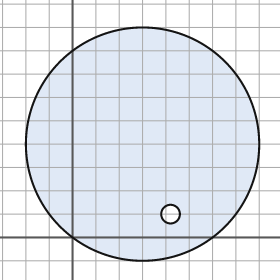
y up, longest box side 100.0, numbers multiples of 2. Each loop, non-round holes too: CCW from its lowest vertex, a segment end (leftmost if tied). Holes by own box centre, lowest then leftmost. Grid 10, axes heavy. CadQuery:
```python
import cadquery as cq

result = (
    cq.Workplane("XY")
    .moveTo(30.0, 40.0)
    .circle(50.0)
    .moveTo(42.0, 10.0)
    .circle(4.0)
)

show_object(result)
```